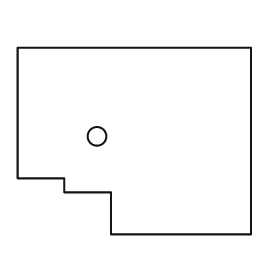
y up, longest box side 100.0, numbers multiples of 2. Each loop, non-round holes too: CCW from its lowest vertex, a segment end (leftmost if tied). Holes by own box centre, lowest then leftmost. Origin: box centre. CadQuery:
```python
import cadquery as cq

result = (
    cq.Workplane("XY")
    .moveTo(-10.0, -40.0)
    .lineTo(50.0, -40.0)
    .lineTo(50.0, 40.0)
    .lineTo(-50.0, 40.0)
    .lineTo(-50.0, -16.0)
    .lineTo(-30.0, -16.0)
    .lineTo(-30.0, -22.0)
    .lineTo(-10.0, -22.0)
    .close()
    .moveTo(-16.0, 2.0)
    .circle(4.0)
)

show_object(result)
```